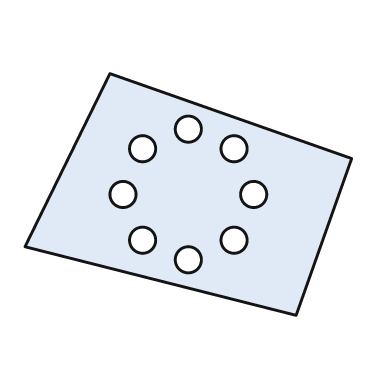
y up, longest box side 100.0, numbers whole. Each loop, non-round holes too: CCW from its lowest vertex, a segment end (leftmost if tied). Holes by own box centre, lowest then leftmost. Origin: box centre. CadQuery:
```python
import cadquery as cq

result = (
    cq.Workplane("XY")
    .moveTo(33.0, -37.0)
    .lineTo(50.0, 11.0)
    .lineTo(-24.0, 37.0)
    .lineTo(-50.0, -16.0)
    .close()
    .moveTo(0.0, -20.0)
    .circle(4.0)
    .moveTo(-14.0, -14.0)
    .circle(4.0)
    .moveTo(14.0, -14.0)
    .circle(4.0)
    .moveTo(-20.0, 0.0)
    .circle(4.0)
    .moveTo(20.0, 0.0)
    .circle(4.0)
    .moveTo(-14.0, 14.0)
    .circle(4.0)
    .moveTo(14.0, 14.0)
    .circle(4.0)
    .moveTo(0.0, 20.0)
    .circle(4.0)
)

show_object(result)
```